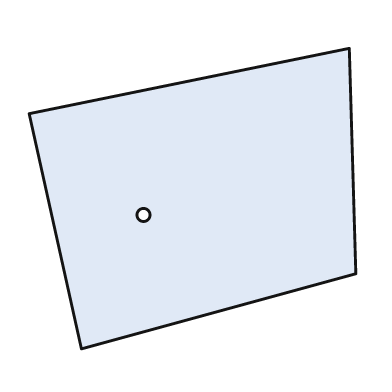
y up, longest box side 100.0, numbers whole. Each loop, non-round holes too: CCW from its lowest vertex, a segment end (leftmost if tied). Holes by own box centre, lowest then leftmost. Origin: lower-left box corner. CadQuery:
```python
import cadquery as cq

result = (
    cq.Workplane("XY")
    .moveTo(16.0, 0.0)
    .lineTo(100.0, 23.0)
    .lineTo(98.0, 92.0)
    .lineTo(0.0, 72.0)
    .close()
    .moveTo(35.0, 41.0)
    .circle(2.0)
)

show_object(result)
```